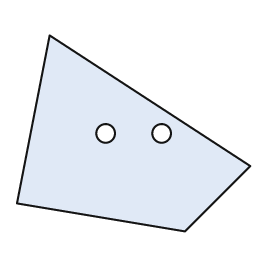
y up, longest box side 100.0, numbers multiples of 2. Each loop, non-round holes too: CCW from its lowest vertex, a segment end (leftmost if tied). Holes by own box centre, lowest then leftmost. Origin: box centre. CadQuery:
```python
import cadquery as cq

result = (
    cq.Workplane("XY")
    .moveTo(22.0, -42.0)
    .lineTo(50.0, -14.0)
    .lineTo(-36.0, 42.0)
    .lineTo(-50.0, -30.0)
    .close()
    .moveTo(-12.0, 0.0)
    .circle(4.0)
    .moveTo(12.0, 0.0)
    .circle(4.0)
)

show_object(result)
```